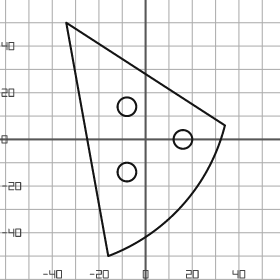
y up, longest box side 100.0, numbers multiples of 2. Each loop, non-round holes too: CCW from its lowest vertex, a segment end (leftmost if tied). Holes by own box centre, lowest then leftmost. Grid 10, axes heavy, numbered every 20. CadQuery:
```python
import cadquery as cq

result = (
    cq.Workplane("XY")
    .moveTo(-16.0, -50.0)
    .threePointArc((16.0, -28.0), (34.0, 6.0))
    .lineTo(-34.0, 50.0)
    .close()
    .moveTo(-8.0, -14.0)
    .circle(4.0)
    .moveTo(16.0, 0.0)
    .circle(4.0)
    .moveTo(-8.0, 14.0)
    .circle(4.0)
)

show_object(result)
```